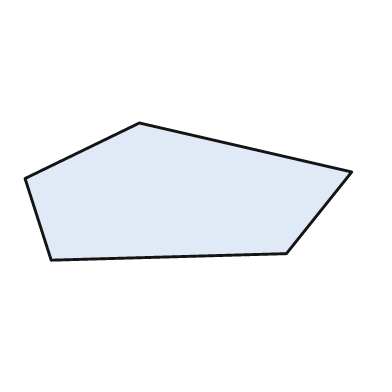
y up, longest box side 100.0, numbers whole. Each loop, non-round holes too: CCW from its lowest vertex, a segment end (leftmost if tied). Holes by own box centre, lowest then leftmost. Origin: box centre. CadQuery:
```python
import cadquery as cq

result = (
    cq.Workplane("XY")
    .moveTo(-42.0, -21.0)
    .lineTo(30.0, -19.0)
    .lineTo(50.0, 6.0)
    .lineTo(-15.0, 21.0)
    .lineTo(-50.0, 4.0)
    .close()
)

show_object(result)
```